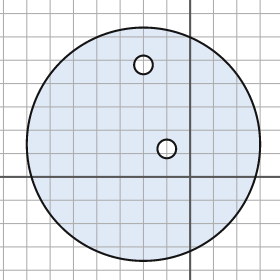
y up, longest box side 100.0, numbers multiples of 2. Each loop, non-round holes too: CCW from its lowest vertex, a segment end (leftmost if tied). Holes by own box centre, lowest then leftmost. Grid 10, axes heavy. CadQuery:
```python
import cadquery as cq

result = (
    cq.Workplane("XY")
    .moveTo(-20.0, 14.0)
    .circle(50.0)
    .moveTo(-10.0, 12.0)
    .circle(4.0)
    .moveTo(-20.0, 48.0)
    .circle(4.0)
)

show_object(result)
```